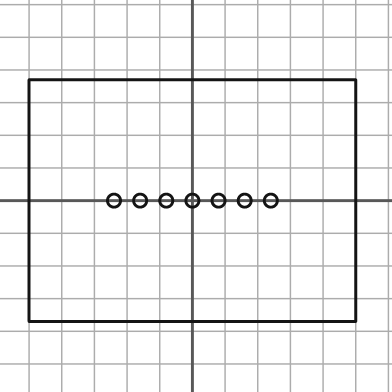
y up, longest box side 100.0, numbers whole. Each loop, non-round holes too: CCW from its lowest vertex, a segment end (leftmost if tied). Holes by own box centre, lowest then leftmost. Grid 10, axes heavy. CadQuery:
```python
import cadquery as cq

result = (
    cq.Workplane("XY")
    .moveTo(-50.0, -37.0)
    .lineTo(50.0, -37.0)
    .lineTo(50.0, 37.0)
    .lineTo(-50.0, 37.0)
    .close()
    .moveTo(-24.0, 0.0)
    .circle(2.0)
    .moveTo(-16.0, 0.0)
    .circle(2.0)
    .moveTo(-8.0, 0.0)
    .circle(2.0)
    .moveTo(0.0, 0.0)
    .circle(2.0)
    .moveTo(8.0, 0.0)
    .circle(2.0)
    .moveTo(16.0, 0.0)
    .circle(2.0)
    .moveTo(24.0, 0.0)
    .circle(2.0)
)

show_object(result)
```